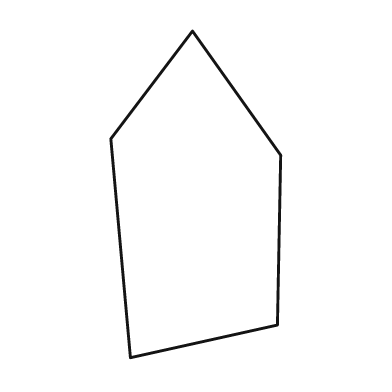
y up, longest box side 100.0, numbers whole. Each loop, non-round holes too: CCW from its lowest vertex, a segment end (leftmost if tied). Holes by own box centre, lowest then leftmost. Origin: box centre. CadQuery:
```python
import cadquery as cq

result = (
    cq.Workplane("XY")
    .moveTo(-20.0, -50.0)
    .lineTo(25.0, -40.0)
    .lineTo(26.0, 12.0)
    .lineTo(-1.0, 50.0)
    .lineTo(-26.0, 17.0)
    .close()
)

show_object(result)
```